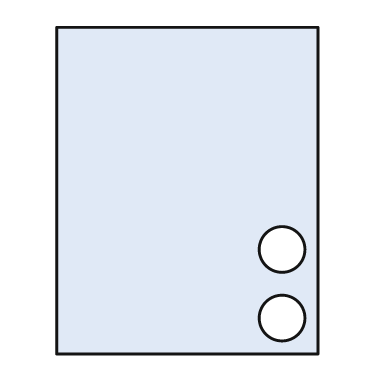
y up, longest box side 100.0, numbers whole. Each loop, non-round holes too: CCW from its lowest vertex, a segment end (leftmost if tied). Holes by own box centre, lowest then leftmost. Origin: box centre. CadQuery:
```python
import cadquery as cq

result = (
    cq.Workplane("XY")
    .moveTo(-40.0, -50.0)
    .lineTo(40.0, -50.0)
    .lineTo(40.0, 50.0)
    .lineTo(-40.0, 50.0)
    .close()
    .moveTo(29.0, -39.0)
    .circle(7.0)
    .moveTo(29.0, -18.0)
    .circle(7.0)
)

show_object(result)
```